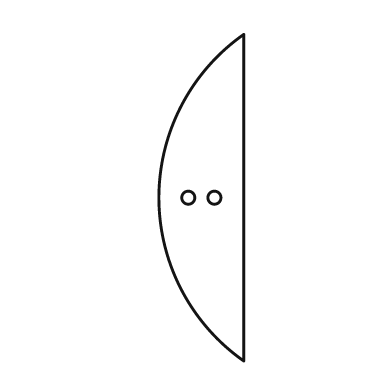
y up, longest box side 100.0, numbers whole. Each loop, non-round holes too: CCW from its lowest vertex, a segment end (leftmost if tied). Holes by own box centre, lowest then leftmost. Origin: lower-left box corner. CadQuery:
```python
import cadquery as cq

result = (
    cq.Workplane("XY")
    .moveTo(26.0, 0.0)
    .lineTo(26.0, 100.0)
    .threePointArc((0.0, 50.0), (26.0, 0.0))
    .close()
    .moveTo(9.0, 50.0)
    .circle(2.0)
    .moveTo(17.0, 50.0)
    .circle(2.0)
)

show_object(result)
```